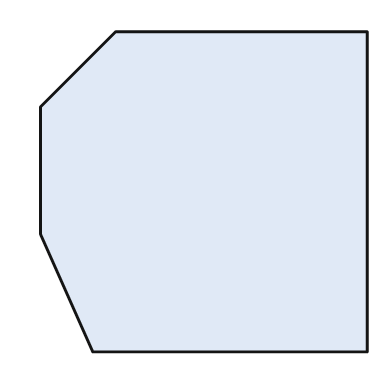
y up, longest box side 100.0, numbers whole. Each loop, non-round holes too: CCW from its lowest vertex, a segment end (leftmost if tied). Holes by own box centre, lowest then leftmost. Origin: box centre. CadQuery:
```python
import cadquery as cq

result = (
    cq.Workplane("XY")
    .moveTo(-34.0, -49.0)
    .lineTo(50.0, -49.0)
    .lineTo(50.0, 49.0)
    .lineTo(-27.0, 49.0)
    .lineTo(-50.0, 26.0)
    .lineTo(-50.0, -13.0)
    .close()
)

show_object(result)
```